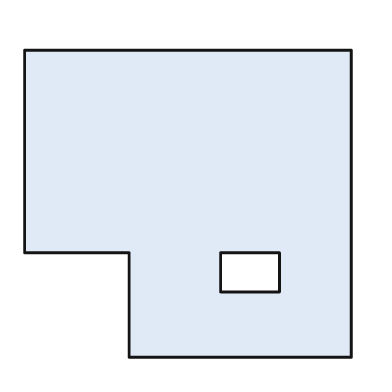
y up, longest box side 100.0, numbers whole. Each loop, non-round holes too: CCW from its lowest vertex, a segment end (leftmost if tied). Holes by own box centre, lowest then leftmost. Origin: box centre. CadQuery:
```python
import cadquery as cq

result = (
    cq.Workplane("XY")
    .moveTo(-18.0, -47.0)
    .lineTo(50.0, -47.0)
    .lineTo(50.0, 47.0)
    .lineTo(-50.0, 47.0)
    .lineTo(-50.0, -15.0)
    .lineTo(-18.0, -15.0)
    .close()
    .moveTo(10.0, -27.0)
    .lineTo(28.0, -27.0)
    .lineTo(28.0, -15.0)
    .lineTo(10.0, -15.0)
    .close()
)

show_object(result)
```